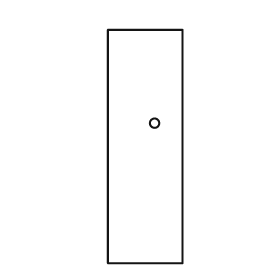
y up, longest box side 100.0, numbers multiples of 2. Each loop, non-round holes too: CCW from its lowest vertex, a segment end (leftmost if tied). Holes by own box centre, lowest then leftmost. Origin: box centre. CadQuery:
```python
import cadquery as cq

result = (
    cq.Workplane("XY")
    .moveTo(-16.0, -50.0)
    .lineTo(16.0, -50.0)
    .lineTo(16.0, 50.0)
    .lineTo(-16.0, 50.0)
    .close()
    .moveTo(4.0, 10.0)
    .circle(2.0)
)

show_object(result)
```